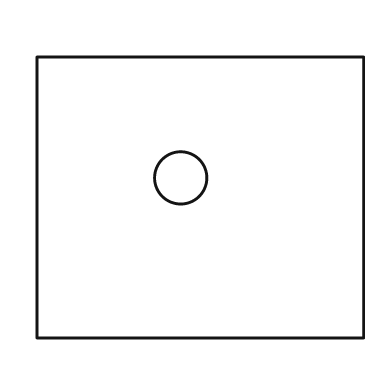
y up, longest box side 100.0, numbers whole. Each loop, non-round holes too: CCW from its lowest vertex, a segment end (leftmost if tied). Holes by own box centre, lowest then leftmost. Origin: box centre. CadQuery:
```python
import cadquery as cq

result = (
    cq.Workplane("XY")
    .moveTo(-50.0, -43.0)
    .lineTo(50.0, -43.0)
    .lineTo(50.0, 43.0)
    .lineTo(-50.0, 43.0)
    .close()
    .moveTo(-6.0, 6.0)
    .circle(8.0)
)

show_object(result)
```